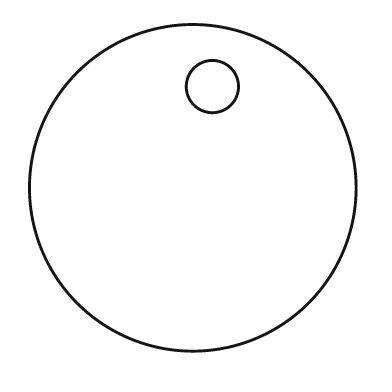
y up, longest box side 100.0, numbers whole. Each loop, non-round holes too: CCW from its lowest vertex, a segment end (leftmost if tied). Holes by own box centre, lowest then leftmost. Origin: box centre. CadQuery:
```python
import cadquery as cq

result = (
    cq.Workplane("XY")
    .moveTo(0.0, 0.0)
    .circle(50.0)
    .moveTo(6.0, 31.0)
    .circle(8.0)
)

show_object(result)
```